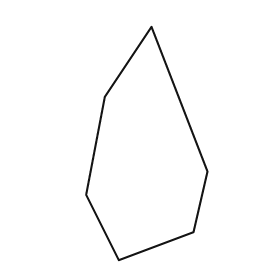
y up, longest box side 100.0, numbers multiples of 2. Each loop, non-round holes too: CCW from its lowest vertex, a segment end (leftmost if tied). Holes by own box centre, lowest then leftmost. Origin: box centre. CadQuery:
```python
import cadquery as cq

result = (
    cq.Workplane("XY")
    .moveTo(-12.0, -50.0)
    .lineTo(20.0, -38.0)
    .lineTo(26.0, -12.0)
    .lineTo(2.0, 50.0)
    .lineTo(-18.0, 20.0)
    .lineTo(-26.0, -22.0)
    .close()
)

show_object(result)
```